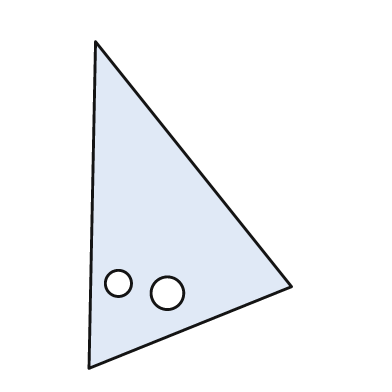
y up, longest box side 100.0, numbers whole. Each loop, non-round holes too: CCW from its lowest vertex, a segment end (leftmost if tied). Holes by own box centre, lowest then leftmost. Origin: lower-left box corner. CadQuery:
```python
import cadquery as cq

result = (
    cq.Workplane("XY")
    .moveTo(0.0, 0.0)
    .lineTo(62.0, 25.0)
    .lineTo(2.0, 100.0)
    .close()
    .moveTo(24.0, 23.0)
    .circle(5.0)
    .moveTo(9.0, 26.0)
    .circle(4.0)
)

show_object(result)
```